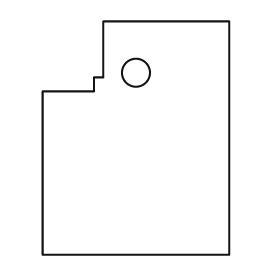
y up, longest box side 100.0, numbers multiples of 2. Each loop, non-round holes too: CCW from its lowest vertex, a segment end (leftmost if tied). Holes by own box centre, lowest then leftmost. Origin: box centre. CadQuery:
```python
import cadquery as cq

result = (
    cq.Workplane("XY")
    .moveTo(-40.0, -50.0)
    .lineTo(40.0, -50.0)
    .lineTo(40.0, 50.0)
    .lineTo(-14.0, 50.0)
    .lineTo(-14.0, 26.0)
    .lineTo(-18.0, 26.0)
    .lineTo(-18.0, 20.0)
    .lineTo(-40.0, 20.0)
    .close()
    .moveTo(0.0, 28.0)
    .circle(6.0)
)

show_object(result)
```